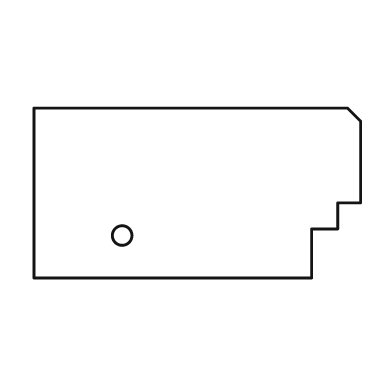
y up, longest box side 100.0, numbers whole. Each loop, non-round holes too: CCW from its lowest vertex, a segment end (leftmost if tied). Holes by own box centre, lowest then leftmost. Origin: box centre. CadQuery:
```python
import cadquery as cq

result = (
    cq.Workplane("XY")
    .moveTo(-50.0, -26.0)
    .lineTo(35.0, -26.0)
    .lineTo(35.0, -11.0)
    .lineTo(43.0, -11.0)
    .lineTo(43.0, -3.0)
    .lineTo(50.0, -3.0)
    .lineTo(50.0, 22.0)
    .lineTo(46.0, 26.0)
    .lineTo(-50.0, 26.0)
    .close()
    .moveTo(-23.0, -13.0)
    .circle(3.0)
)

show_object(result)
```